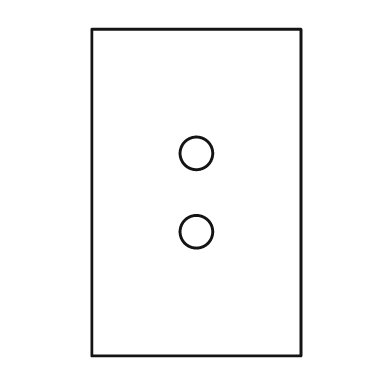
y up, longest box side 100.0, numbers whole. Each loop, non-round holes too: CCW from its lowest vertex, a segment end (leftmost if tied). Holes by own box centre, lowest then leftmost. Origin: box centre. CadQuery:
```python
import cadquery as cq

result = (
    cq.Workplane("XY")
    .moveTo(-32.0, -50.0)
    .lineTo(32.0, -50.0)
    .lineTo(32.0, 50.0)
    .lineTo(-32.0, 50.0)
    .close()
    .moveTo(0.0, -12.0)
    .circle(5.0)
    .moveTo(0.0, 12.0)
    .circle(5.0)
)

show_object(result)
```